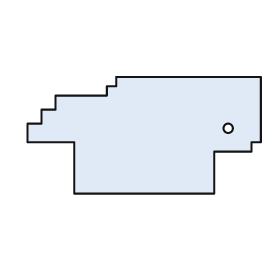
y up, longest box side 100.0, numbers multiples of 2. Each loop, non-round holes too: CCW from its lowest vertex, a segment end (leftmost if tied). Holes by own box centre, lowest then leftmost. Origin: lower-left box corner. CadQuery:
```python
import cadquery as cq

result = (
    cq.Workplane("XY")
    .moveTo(20.0, 0.0)
    .lineTo(80.0, 0.0)
    .lineTo(80.0, 18.0)
    .lineTo(96.0, 18.0)
    .lineTo(96.0, 22.0)
    .lineTo(100.0, 22.0)
    .lineTo(100.0, 50.0)
    .lineTo(38.0, 50.0)
    .lineTo(38.0, 46.0)
    .lineTo(34.0, 46.0)
    .lineTo(34.0, 42.0)
    .lineTo(12.0, 42.0)
    .lineTo(12.0, 36.0)
    .lineTo(6.0, 36.0)
    .lineTo(6.0, 30.0)
    .lineTo(0.0, 30.0)
    .lineTo(0.0, 22.0)
    .lineTo(20.0, 22.0)
    .close()
    .moveTo(86.0, 28.0)
    .circle(2.0)
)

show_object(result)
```